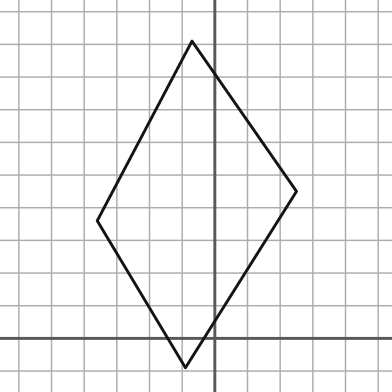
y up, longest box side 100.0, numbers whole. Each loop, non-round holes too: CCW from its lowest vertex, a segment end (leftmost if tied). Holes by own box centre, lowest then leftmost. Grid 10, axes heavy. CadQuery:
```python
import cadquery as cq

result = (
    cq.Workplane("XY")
    .moveTo(-9.0, -9.0)
    .lineTo(25.0, 45.0)
    .lineTo(-7.0, 91.0)
    .lineTo(-36.0, 36.0)
    .close()
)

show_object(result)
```